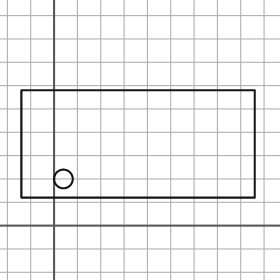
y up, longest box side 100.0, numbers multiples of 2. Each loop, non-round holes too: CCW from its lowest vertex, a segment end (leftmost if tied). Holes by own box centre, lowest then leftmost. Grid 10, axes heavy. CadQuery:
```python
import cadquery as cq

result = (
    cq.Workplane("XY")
    .moveTo(-14.0, 12.0)
    .lineTo(86.0, 12.0)
    .lineTo(86.0, 58.0)
    .lineTo(-14.0, 58.0)
    .close()
    .moveTo(4.0, 20.0)
    .circle(4.0)
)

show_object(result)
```